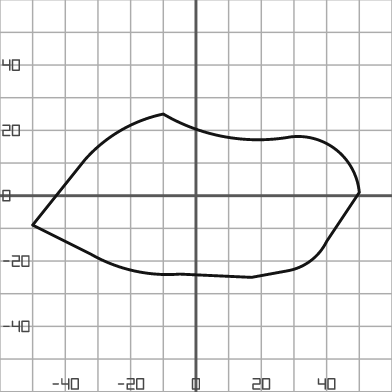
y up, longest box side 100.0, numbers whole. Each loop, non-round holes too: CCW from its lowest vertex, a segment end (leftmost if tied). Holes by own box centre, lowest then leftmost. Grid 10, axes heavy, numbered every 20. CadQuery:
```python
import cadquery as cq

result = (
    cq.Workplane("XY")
    .moveTo(17.0, -25.0)
    .lineTo(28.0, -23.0)
    .threePointArc((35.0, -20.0), (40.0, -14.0))
    .lineTo(50.0, 1.0)
    .threePointArc((43.0, 14.0), (29.0, 18.0))
    .threePointArc((9.0, 18.0), (-10.0, 25.0))
    .threePointArc((-23.0, 20.0), (-34.0, 11.0))
    .lineTo(-50.0, -9.0)
    .lineTo(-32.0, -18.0)
    .threePointArc((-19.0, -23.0), (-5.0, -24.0))
    .close()
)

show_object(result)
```